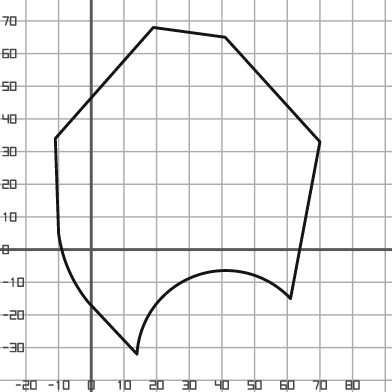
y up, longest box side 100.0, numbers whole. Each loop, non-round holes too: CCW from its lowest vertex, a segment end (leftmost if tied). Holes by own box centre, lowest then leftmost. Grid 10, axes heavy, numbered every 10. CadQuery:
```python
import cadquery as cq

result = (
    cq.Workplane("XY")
    .moveTo(14.0, -32.0)
    .threePointArc((32.0, -8.0), (61.0, -15.0))
    .lineTo(70.0, 33.0)
    .lineTo(41.0, 65.0)
    .lineTo(19.0, 68.0)
    .lineTo(-11.0, 34.0)
    .lineTo(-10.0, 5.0)
    .threePointArc((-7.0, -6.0), (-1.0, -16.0))
    .close()
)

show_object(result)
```